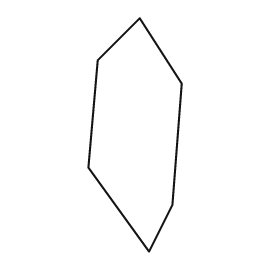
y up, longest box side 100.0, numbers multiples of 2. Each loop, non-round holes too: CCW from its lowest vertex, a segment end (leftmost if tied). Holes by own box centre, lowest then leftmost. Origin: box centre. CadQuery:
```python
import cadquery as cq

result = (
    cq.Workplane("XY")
    .moveTo(6.0, -50.0)
    .lineTo(16.0, -30.0)
    .lineTo(20.0, 22.0)
    .lineTo(2.0, 50.0)
    .lineTo(-16.0, 32.0)
    .lineTo(-20.0, -14.0)
    .close()
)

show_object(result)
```